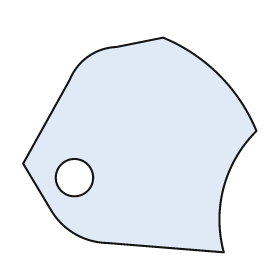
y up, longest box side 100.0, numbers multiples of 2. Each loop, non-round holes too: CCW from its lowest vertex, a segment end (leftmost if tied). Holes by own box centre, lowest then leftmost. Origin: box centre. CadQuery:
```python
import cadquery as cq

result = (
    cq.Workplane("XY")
    .moveTo(36.0, -46.0)
    .threePointArc((36.0, -18.0), (50.0, 6.0))
    .threePointArc((34.0, 30.0), (10.0, 46.0))
    .lineTo(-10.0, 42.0)
    .threePointArc((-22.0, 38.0), (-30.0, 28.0))
    .lineTo(-50.0, -8.0)
    .lineTo(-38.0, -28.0)
    .threePointArc((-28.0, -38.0), (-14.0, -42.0))
    .close()
    .moveTo(-28.0, -14.0)
    .circle(8.0)
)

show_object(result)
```